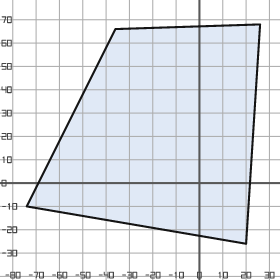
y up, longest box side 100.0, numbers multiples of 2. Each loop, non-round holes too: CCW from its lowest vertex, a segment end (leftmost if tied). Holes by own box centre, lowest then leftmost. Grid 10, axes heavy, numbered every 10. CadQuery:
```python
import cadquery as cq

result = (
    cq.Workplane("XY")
    .moveTo(20.0, -26.0)
    .lineTo(26.0, 68.0)
    .lineTo(-36.0, 66.0)
    .lineTo(-74.0, -10.0)
    .close()
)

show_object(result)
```